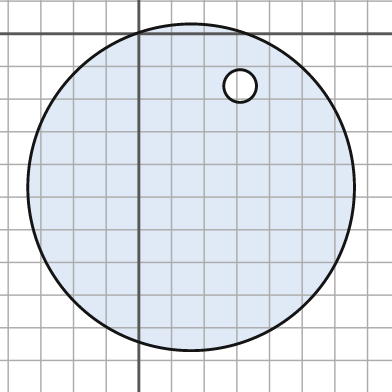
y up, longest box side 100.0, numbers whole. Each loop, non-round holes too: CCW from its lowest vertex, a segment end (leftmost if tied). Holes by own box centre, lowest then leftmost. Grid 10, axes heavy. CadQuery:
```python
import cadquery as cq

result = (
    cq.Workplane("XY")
    .moveTo(16.0, -47.0)
    .circle(50.0)
    .moveTo(31.0, -16.0)
    .circle(5.0)
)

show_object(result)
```